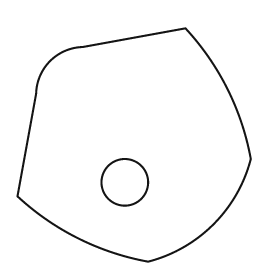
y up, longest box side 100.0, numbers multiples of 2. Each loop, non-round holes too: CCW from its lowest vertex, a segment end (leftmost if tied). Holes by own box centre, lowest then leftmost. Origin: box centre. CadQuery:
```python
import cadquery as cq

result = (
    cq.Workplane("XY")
    .moveTo(6.0, -50.0)
    .threePointArc((34.0, -34.0), (50.0, -6.0))
    .threePointArc((40.0, 24.0), (22.0, 50.0))
    .lineTo(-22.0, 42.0)
    .threePointArc((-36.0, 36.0), (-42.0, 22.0))
    .lineTo(-50.0, -22.0)
    .threePointArc((-24.0, -40.0), (6.0, -50.0))
    .close()
    .moveTo(-4.0, -16.0)
    .circle(10.0)
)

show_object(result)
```